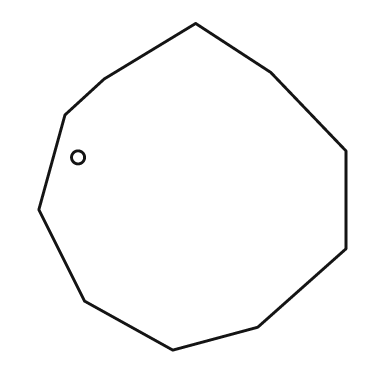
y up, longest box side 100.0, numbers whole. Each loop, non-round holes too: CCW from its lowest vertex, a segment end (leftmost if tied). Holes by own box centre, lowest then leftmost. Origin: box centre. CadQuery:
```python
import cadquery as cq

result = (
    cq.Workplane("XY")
    .moveTo(-6.0, -50.0)
    .lineTo(20.0, -43.0)
    .lineTo(47.0, -19.0)
    .lineTo(47.0, 11.0)
    .lineTo(24.0, 35.0)
    .lineTo(1.0, 50.0)
    .lineTo(-27.0, 33.0)
    .lineTo(-39.0, 22.0)
    .lineTo(-47.0, -7.0)
    .lineTo(-33.0, -35.0)
    .close()
    .moveTo(-35.0, 9.0)
    .circle(2.0)
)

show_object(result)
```